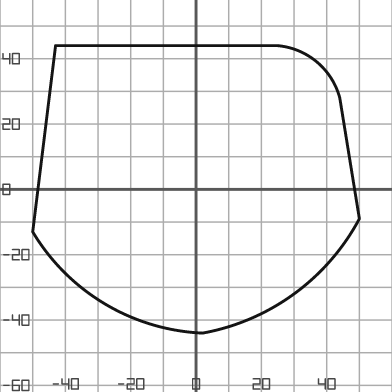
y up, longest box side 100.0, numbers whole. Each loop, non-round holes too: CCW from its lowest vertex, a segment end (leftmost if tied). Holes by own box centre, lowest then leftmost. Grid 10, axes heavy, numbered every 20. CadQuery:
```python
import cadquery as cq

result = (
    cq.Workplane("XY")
    .moveTo(2.0, -44.0)
    .threePointArc((30.0, -32.0), (50.0, -9.0))
    .lineTo(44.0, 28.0)
    .threePointArc((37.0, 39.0), (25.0, 44.0))
    .lineTo(-43.0, 44.0)
    .lineTo(-50.0, -13.0)
    .threePointArc((-28.0, -35.0), (2.0, -44.0))
    .close()
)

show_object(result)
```